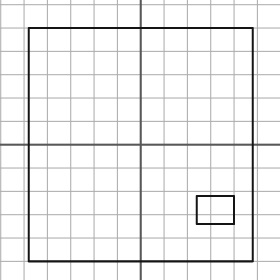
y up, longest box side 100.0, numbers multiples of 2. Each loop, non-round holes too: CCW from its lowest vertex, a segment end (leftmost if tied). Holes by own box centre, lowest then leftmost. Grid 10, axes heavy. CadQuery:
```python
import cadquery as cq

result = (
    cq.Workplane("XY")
    .moveTo(-48.0, -50.0)
    .lineTo(48.0, -50.0)
    .lineTo(48.0, 50.0)
    .lineTo(-48.0, 50.0)
    .close()
    .moveTo(24.0, -34.0)
    .lineTo(40.0, -34.0)
    .lineTo(40.0, -22.0)
    .lineTo(24.0, -22.0)
    .close()
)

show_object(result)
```